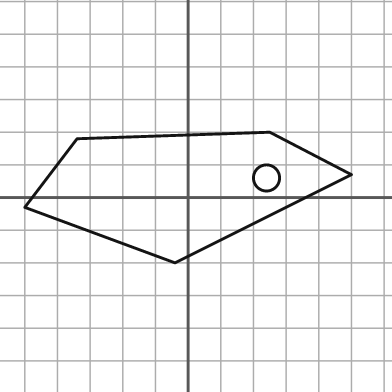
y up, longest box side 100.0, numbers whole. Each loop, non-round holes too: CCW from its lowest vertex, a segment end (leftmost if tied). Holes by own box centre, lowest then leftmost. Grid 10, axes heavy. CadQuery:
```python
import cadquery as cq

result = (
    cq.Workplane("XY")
    .moveTo(-4.0, -20.0)
    .lineTo(50.0, 7.0)
    .lineTo(25.0, 20.0)
    .lineTo(-34.0, 18.0)
    .lineTo(-50.0, -3.0)
    .close()
    .moveTo(24.0, 6.0)
    .circle(4.0)
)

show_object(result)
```